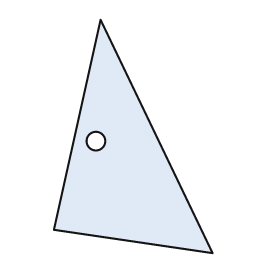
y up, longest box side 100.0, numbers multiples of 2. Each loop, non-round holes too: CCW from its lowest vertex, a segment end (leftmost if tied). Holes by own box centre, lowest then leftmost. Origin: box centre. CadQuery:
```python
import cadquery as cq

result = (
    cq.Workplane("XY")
    .moveTo(34.0, -50.0)
    .lineTo(-14.0, 50.0)
    .lineTo(-34.0, -40.0)
    .close()
    .moveTo(-16.0, -2.0)
    .circle(4.0)
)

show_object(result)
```